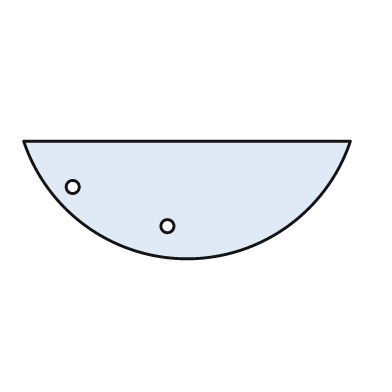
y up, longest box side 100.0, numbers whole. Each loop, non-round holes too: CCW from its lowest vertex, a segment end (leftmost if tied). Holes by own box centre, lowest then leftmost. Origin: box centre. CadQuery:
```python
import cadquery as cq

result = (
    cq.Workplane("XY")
    .moveTo(-50.0, 18.0)
    .threePointArc((0.0, -18.0), (50.0, 18.0))
    .close()
    .moveTo(-6.0, -8.0)
    .circle(2.0)
    .moveTo(-35.0, 4.0)
    .circle(2.0)
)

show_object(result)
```